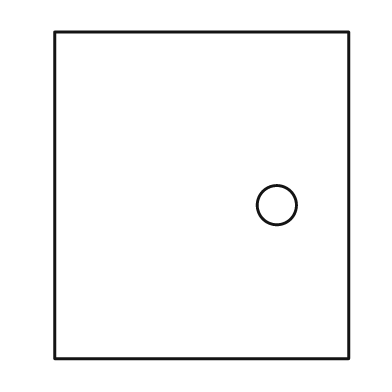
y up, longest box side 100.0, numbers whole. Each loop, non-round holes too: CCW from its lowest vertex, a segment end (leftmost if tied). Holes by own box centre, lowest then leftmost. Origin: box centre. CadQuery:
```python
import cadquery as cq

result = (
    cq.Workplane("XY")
    .moveTo(-45.0, -50.0)
    .lineTo(45.0, -50.0)
    .lineTo(45.0, 50.0)
    .lineTo(-45.0, 50.0)
    .close()
    .moveTo(23.0, -3.0)
    .circle(6.0)
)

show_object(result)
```